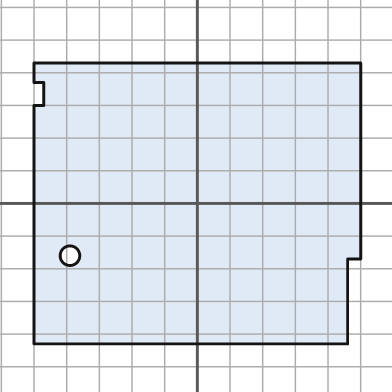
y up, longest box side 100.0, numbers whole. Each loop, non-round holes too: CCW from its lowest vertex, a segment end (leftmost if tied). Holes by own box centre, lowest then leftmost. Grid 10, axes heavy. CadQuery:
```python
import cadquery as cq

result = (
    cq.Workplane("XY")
    .moveTo(-50.0, -43.0)
    .lineTo(46.0, -43.0)
    .lineTo(46.0, -17.0)
    .lineTo(50.0, -17.0)
    .lineTo(50.0, 43.0)
    .lineTo(-50.0, 43.0)
    .lineTo(-50.0, 37.0)
    .lineTo(-47.0, 37.0)
    .lineTo(-47.0, 30.0)
    .lineTo(-50.0, 30.0)
    .close()
    .moveTo(-39.0, -16.0)
    .circle(3.0)
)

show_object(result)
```